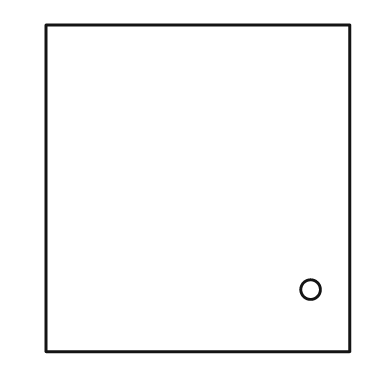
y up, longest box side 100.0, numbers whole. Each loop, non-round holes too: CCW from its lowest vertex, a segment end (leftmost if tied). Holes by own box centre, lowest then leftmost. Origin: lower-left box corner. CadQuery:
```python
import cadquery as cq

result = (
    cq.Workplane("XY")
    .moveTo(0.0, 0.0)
    .lineTo(93.0, 0.0)
    .lineTo(93.0, 100.0)
    .lineTo(0.0, 100.0)
    .close()
    .moveTo(81.0, 19.0)
    .circle(3.0)
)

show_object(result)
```